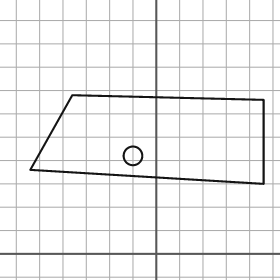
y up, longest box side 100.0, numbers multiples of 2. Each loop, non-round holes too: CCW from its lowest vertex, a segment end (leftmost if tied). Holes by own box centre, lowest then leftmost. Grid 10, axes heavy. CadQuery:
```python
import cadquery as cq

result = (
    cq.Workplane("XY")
    .moveTo(46.0, 30.0)
    .lineTo(46.0, 66.0)
    .lineTo(-36.0, 68.0)
    .lineTo(-54.0, 36.0)
    .close()
    .moveTo(-10.0, 42.0)
    .circle(4.0)
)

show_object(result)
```